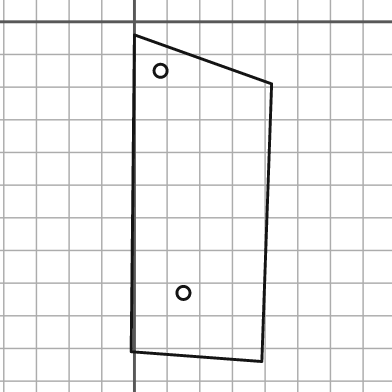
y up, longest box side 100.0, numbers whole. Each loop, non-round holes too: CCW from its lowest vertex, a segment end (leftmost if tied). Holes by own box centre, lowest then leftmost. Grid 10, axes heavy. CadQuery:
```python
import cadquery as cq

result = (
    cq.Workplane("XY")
    .moveTo(39.0, -104.0)
    .lineTo(42.0, -19.0)
    .lineTo(0.0, -4.0)
    .lineTo(-1.0, -101.0)
    .close()
    .moveTo(15.0, -83.0)
    .circle(2.0)
    .moveTo(8.0, -15.0)
    .circle(2.0)
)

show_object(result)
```